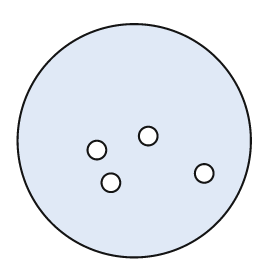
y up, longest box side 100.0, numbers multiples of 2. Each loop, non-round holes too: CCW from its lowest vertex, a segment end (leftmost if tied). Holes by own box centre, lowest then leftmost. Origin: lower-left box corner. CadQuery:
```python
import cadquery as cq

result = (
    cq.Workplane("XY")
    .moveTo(50.0, 50.0)
    .circle(50.0)
    .moveTo(40.0, 32.0)
    .circle(4.0)
    .moveTo(80.0, 36.0)
    .circle(4.0)
    .moveTo(34.0, 46.0)
    .circle(4.0)
    .moveTo(56.0, 52.0)
    .circle(4.0)
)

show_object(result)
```